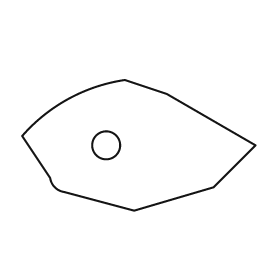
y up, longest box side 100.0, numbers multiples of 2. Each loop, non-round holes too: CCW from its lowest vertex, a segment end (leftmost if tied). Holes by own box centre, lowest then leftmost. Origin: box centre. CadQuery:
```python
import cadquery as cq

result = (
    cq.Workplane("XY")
    .moveTo(-2.0, -28.0)
    .lineTo(32.0, -18.0)
    .lineTo(50.0, 0.0)
    .lineTo(12.0, 22.0)
    .lineTo(-6.0, 28.0)
    .threePointArc((-30.0, 20.0), (-50.0, 4.0))
    .lineTo(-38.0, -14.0)
    .threePointArc((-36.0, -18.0), (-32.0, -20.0))
    .close()
    .moveTo(-14.0, 0.0)
    .circle(6.0)
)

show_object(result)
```